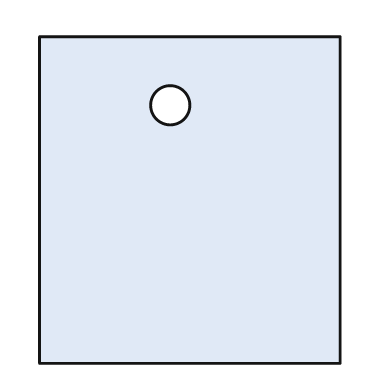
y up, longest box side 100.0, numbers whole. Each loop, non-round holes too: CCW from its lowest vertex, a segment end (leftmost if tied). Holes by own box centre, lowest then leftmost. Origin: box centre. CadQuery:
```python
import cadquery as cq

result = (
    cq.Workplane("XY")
    .moveTo(-46.0, -50.0)
    .lineTo(46.0, -50.0)
    .lineTo(46.0, 50.0)
    .lineTo(-46.0, 50.0)
    .close()
    .moveTo(-6.0, 29.0)
    .circle(6.0)
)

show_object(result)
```